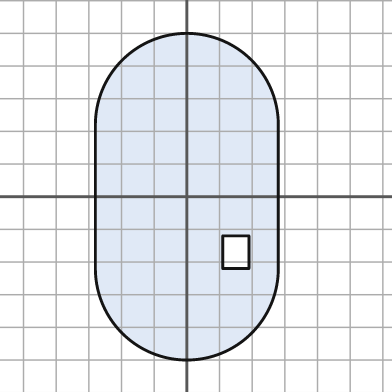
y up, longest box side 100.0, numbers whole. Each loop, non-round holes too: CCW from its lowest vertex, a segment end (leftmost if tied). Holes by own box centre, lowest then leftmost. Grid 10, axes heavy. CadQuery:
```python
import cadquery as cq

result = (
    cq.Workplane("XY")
    .moveTo(-28.0, -22.0)
    .threePointArc((0.0, -50.0), (28.0, -22.0))
    .lineTo(28.0, 22.0)
    .threePointArc((0.0, 50.0), (-28.0, 22.0))
    .close()
    .moveTo(11.0, -22.0)
    .lineTo(19.0, -22.0)
    .lineTo(19.0, -12.0)
    .lineTo(11.0, -12.0)
    .close()
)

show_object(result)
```